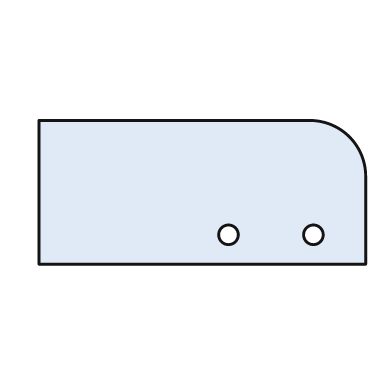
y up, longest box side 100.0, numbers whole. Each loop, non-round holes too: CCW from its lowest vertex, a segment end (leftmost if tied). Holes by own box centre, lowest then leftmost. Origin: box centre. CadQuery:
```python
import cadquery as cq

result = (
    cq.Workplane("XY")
    .moveTo(-50.0, -22.0)
    .lineTo(50.0, -22.0)
    .lineTo(50.0, 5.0)
    .threePointArc((45.0, 17.0), (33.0, 22.0))
    .lineTo(-50.0, 22.0)
    .close()
    .moveTo(8.0, -13.0)
    .circle(3.0)
    .moveTo(34.0, -13.0)
    .circle(3.0)
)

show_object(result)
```